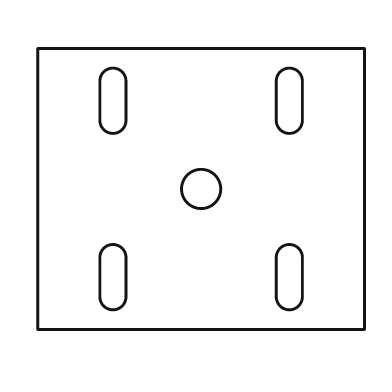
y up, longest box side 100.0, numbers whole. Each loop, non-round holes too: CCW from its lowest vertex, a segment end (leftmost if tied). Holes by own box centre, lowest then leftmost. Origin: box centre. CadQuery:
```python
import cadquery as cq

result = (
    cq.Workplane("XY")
    .moveTo(-50.0, -43.0)
    .lineTo(50.0, -43.0)
    .lineTo(50.0, 43.0)
    .lineTo(-50.0, 43.0)
    .close()
    .moveTo(-31.0, -33.0)
    .threePointArc((-27.0, -37.0), (-23.0, -33.0))
    .lineTo(-23.0, -21.0)
    .threePointArc((-27.0, -17.0), (-31.0, -21.0))
    .close()
    .moveTo(23.0, -33.0)
    .threePointArc((27.0, -37.0), (31.0, -33.0))
    .lineTo(31.0, -21.0)
    .threePointArc((27.0, -17.0), (23.0, -21.0))
    .close()
    .moveTo(0.0, 0.0)
    .circle(6.0)
    .moveTo(-31.0, 21.0)
    .threePointArc((-27.0, 17.0), (-23.0, 21.0))
    .lineTo(-23.0, 33.0)
    .threePointArc((-27.0, 37.0), (-31.0, 33.0))
    .close()
    .moveTo(23.0, 21.0)
    .threePointArc((27.0, 17.0), (31.0, 21.0))
    .lineTo(31.0, 33.0)
    .threePointArc((27.0, 37.0), (23.0, 33.0))
    .close()
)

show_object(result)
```